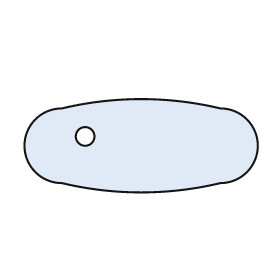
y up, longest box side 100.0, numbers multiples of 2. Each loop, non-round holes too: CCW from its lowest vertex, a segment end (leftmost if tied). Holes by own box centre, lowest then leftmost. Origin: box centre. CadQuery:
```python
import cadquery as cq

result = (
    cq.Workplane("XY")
    .moveTo(-34.0, -16.0)
    .threePointArc((0.0, -20.0), (34.0, -16.0))
    .threePointArc((50.0, 0.0), (34.0, 16.0))
    .threePointArc((0.0, 20.0), (-34.0, 16.0))
    .threePointArc((-50.0, 0.0), (-34.0, -16.0))
    .close()
    .moveTo(-24.0, 4.0)
    .circle(4.0)
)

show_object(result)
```